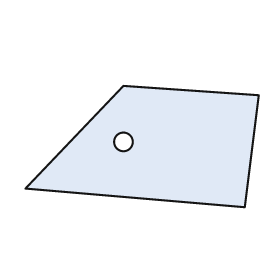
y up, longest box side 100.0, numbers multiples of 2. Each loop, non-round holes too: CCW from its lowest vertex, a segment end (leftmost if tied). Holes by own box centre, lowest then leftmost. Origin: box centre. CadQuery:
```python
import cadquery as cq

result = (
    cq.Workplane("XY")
    .moveTo(44.0, -26.0)
    .lineTo(50.0, 22.0)
    .lineTo(-8.0, 26.0)
    .lineTo(-50.0, -18.0)
    .close()
    .moveTo(-8.0, 2.0)
    .circle(4.0)
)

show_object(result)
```